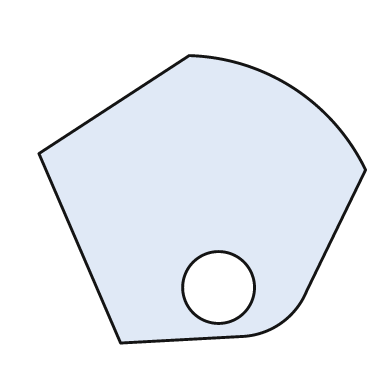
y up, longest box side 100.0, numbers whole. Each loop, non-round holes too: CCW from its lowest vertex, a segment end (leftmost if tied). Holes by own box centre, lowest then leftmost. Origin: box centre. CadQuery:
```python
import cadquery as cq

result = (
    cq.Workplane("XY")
    .moveTo(-25.0, -44.0)
    .lineTo(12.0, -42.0)
    .threePointArc((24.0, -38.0), (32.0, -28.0))
    .lineTo(50.0, 9.0)
    .threePointArc((28.0, 34.0), (-4.0, 44.0))
    .lineTo(-50.0, 14.0)
    .close()
    .moveTo(5.0, -27.0)
    .circle(11.0)
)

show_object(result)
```